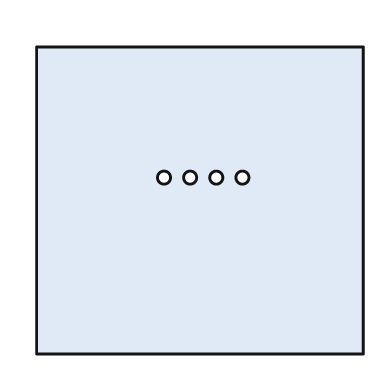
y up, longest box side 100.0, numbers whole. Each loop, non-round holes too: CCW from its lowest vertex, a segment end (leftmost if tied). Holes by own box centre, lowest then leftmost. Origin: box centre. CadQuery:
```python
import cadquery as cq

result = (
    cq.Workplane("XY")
    .moveTo(-50.0, -47.0)
    .lineTo(50.0, -47.0)
    .lineTo(50.0, 47.0)
    .lineTo(-50.0, 47.0)
    .close()
    .moveTo(-11.0, 7.0)
    .circle(2.0)
    .moveTo(-3.0, 7.0)
    .circle(2.0)
    .moveTo(5.0, 7.0)
    .circle(2.0)
    .moveTo(13.0, 7.0)
    .circle(2.0)
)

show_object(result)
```